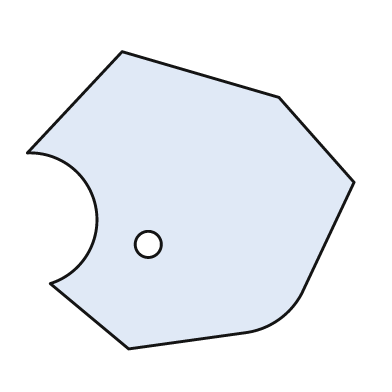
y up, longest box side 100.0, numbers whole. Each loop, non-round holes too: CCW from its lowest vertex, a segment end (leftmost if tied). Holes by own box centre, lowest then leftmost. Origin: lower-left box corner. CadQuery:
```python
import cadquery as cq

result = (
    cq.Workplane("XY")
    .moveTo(31.0, 0.0)
    .lineTo(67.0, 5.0)
    .threePointArc((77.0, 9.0), (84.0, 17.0))
    .lineTo(100.0, 51.0)
    .lineTo(77.0, 77.0)
    .lineTo(29.0, 91.0)
    .lineTo(0.0, 60.0)
    .threePointArc((21.0, 43.0), (7.0, 20.0))
    .close()
    .moveTo(37.0, 32.0)
    .circle(4.0)
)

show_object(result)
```